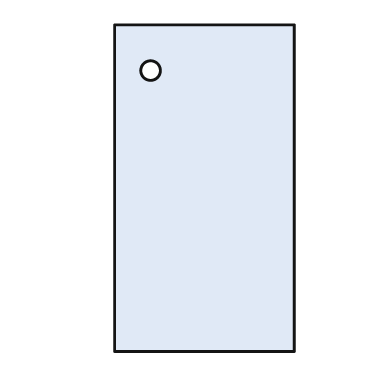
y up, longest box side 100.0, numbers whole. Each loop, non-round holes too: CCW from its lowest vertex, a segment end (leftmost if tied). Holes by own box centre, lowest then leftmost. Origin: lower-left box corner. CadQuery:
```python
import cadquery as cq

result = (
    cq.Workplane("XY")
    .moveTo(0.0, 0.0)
    .lineTo(55.0, 0.0)
    .lineTo(55.0, 100.0)
    .lineTo(0.0, 100.0)
    .close()
    .moveTo(11.0, 86.0)
    .circle(3.0)
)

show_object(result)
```